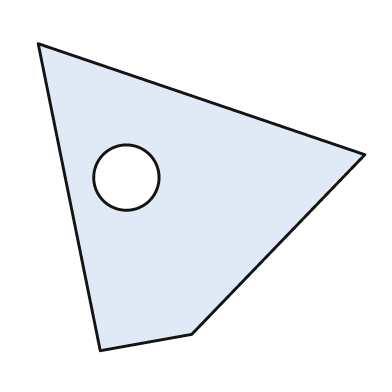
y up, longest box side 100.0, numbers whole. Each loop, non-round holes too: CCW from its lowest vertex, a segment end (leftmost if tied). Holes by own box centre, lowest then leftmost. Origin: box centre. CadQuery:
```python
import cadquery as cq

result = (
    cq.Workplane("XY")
    .moveTo(-31.0, -47.0)
    .lineTo(-3.0, -42.0)
    .lineTo(50.0, 13.0)
    .lineTo(-50.0, 47.0)
    .close()
    .moveTo(-23.0, 6.0)
    .circle(10.0)
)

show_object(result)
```